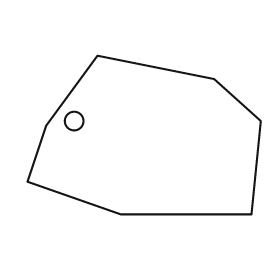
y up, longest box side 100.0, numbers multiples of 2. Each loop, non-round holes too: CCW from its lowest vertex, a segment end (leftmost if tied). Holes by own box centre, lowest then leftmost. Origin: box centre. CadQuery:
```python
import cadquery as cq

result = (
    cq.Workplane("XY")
    .moveTo(-10.0, -34.0)
    .lineTo(46.0, -34.0)
    .lineTo(50.0, 6.0)
    .lineTo(30.0, 24.0)
    .lineTo(-20.0, 34.0)
    .lineTo(-42.0, 4.0)
    .lineTo(-50.0, -20.0)
    .close()
    .moveTo(-30.0, 6.0)
    .circle(4.0)
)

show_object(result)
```